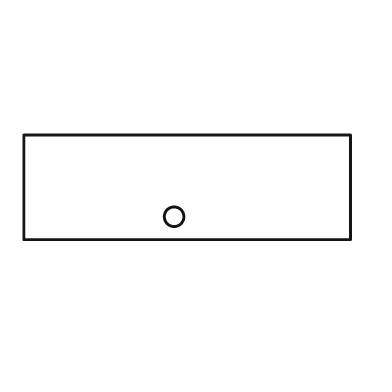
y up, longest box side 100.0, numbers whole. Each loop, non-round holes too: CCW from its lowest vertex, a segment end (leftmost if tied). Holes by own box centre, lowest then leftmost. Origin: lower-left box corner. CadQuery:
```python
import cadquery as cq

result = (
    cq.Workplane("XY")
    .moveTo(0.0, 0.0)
    .lineTo(100.0, 0.0)
    .lineTo(100.0, 32.0)
    .lineTo(0.0, 32.0)
    .close()
    .moveTo(46.0, 7.0)
    .circle(3.0)
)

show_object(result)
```